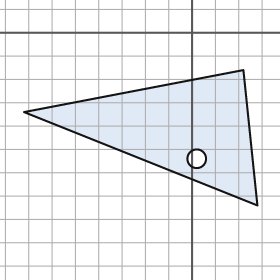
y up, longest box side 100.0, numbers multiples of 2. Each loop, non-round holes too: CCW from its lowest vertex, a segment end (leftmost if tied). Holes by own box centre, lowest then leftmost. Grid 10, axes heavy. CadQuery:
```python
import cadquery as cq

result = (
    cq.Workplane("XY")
    .moveTo(28.0, -74.0)
    .lineTo(22.0, -16.0)
    .lineTo(-72.0, -34.0)
    .close()
    .moveTo(2.0, -54.0)
    .circle(4.0)
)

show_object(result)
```